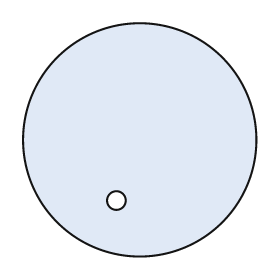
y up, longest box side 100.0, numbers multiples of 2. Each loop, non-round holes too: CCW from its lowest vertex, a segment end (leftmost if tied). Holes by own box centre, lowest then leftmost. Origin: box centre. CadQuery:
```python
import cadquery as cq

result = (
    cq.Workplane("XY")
    .moveTo(0.0, 0.0)
    .circle(50.0)
    .moveTo(-10.0, -26.0)
    .circle(4.0)
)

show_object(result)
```